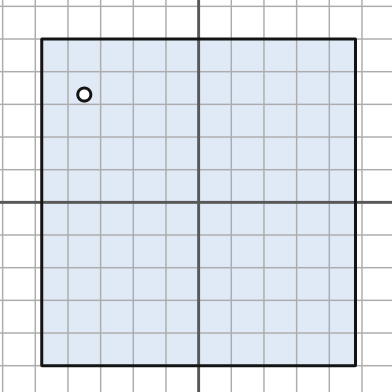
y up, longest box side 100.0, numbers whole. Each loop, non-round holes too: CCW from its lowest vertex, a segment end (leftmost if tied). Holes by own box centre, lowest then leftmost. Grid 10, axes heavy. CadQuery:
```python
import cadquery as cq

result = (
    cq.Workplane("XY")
    .moveTo(-48.0, -50.0)
    .lineTo(48.0, -50.0)
    .lineTo(48.0, 50.0)
    .lineTo(-48.0, 50.0)
    .close()
    .moveTo(-35.0, 33.0)
    .circle(2.0)
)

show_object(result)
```